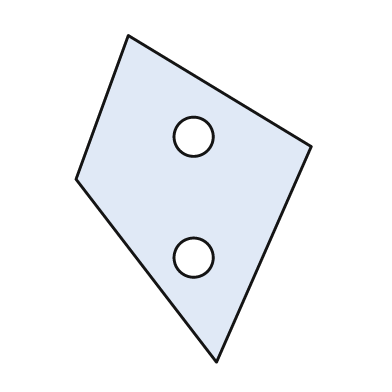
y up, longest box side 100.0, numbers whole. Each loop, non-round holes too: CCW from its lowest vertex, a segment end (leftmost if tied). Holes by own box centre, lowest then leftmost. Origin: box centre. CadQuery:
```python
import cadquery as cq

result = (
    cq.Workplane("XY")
    .moveTo(7.0, -50.0)
    .lineTo(36.0, 16.0)
    .lineTo(-20.0, 50.0)
    .lineTo(-36.0, 6.0)
    .close()
    .moveTo(0.0, -18.0)
    .circle(6.0)
    .moveTo(0.0, 19.0)
    .circle(6.0)
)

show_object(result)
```